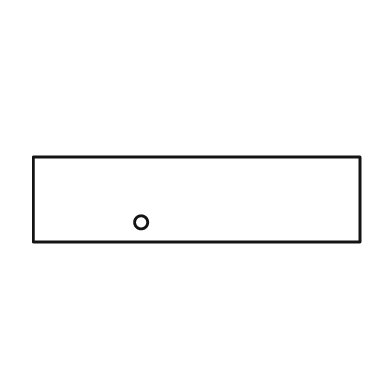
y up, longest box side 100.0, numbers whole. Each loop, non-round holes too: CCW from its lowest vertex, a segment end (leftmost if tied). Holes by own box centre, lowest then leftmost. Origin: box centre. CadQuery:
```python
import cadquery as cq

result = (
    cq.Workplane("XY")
    .moveTo(-50.0, -13.0)
    .lineTo(50.0, -13.0)
    .lineTo(50.0, 13.0)
    .lineTo(-50.0, 13.0)
    .close()
    .moveTo(-17.0, -7.0)
    .circle(2.0)
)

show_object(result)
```